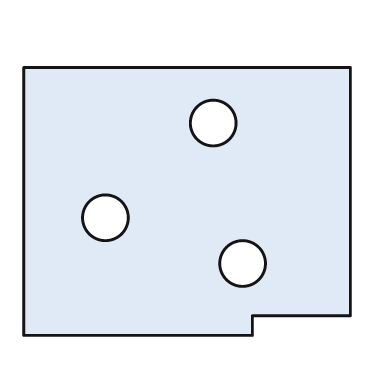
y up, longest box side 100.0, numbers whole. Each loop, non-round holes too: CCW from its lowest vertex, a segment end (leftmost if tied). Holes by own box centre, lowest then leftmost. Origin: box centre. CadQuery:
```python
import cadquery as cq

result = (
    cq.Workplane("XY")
    .moveTo(-50.0, -41.0)
    .lineTo(20.0, -41.0)
    .lineTo(20.0, -35.0)
    .lineTo(50.0, -35.0)
    .lineTo(50.0, 41.0)
    .lineTo(-50.0, 41.0)
    .close()
    .moveTo(17.0, -19.0)
    .circle(7.0)
    .moveTo(-25.0, -5.0)
    .circle(7.0)
    .moveTo(8.0, 24.0)
    .circle(7.0)
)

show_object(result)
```